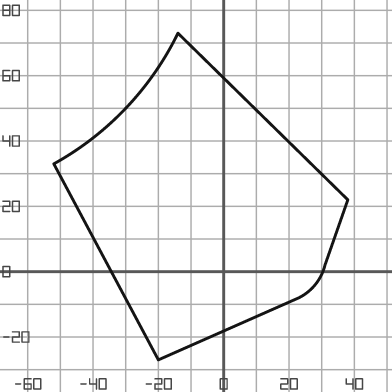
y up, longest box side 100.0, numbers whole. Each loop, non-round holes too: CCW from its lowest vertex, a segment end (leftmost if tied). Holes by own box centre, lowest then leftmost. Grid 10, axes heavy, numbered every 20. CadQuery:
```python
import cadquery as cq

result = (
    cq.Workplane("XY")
    .moveTo(-20.0, -27.0)
    .lineTo(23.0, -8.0)
    .threePointArc((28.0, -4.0), (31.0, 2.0))
    .lineTo(38.0, 22.0)
    .lineTo(-14.0, 73.0)
    .threePointArc((-30.0, 50.0), (-52.0, 33.0))
    .close()
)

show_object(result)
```